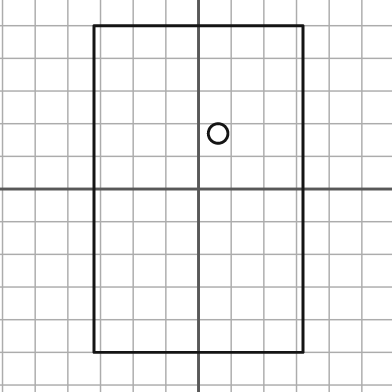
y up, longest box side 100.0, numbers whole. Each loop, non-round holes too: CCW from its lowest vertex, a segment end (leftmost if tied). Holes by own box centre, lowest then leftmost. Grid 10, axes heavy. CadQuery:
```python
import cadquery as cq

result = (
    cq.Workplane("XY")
    .moveTo(-32.0, -50.0)
    .lineTo(32.0, -50.0)
    .lineTo(32.0, 50.0)
    .lineTo(-32.0, 50.0)
    .close()
    .moveTo(6.0, 17.0)
    .circle(3.0)
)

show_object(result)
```